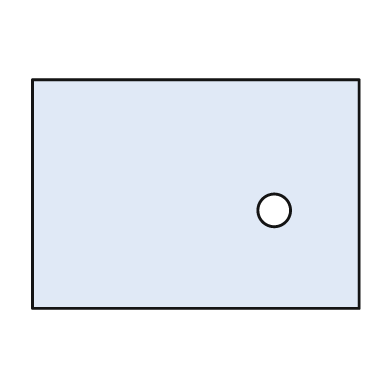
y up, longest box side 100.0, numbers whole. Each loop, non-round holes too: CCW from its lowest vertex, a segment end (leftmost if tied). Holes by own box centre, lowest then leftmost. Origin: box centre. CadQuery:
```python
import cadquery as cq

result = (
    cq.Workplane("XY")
    .moveTo(-50.0, -35.0)
    .lineTo(50.0, -35.0)
    .lineTo(50.0, 35.0)
    .lineTo(-50.0, 35.0)
    .close()
    .moveTo(24.0, -5.0)
    .circle(5.0)
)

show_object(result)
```